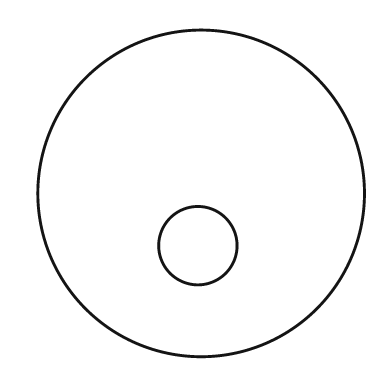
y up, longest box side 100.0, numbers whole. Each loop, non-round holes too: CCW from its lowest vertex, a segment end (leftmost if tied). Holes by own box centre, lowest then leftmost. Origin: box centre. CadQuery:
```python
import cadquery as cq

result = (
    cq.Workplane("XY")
    .moveTo(0.0, 0.0)
    .circle(50.0)
    .moveTo(-1.0, -16.0)
    .circle(12.0)
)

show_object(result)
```